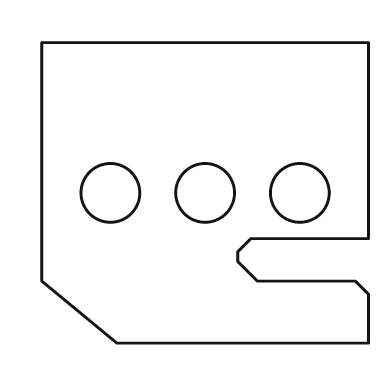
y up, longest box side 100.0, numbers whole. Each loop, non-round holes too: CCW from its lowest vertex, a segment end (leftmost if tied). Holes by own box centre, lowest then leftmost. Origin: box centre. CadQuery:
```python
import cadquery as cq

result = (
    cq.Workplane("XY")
    .moveTo(-27.0, -46.0)
    .lineTo(50.0, -46.0)
    .lineTo(50.0, -31.0)
    .lineTo(46.0, -27.0)
    .lineTo(16.0, -27.0)
    .lineTo(10.0, -21.0)
    .lineTo(10.0, -18.0)
    .lineTo(14.0, -14.0)
    .lineTo(50.0, -14.0)
    .lineTo(50.0, 46.0)
    .lineTo(-50.0, 46.0)
    .lineTo(-50.0, -27.0)
    .close()
    .moveTo(-29.0, 0.0)
    .circle(9.0)
    .moveTo(0.0, 0.0)
    .circle(9.0)
    .moveTo(29.0, 0.0)
    .circle(9.0)
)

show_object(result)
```